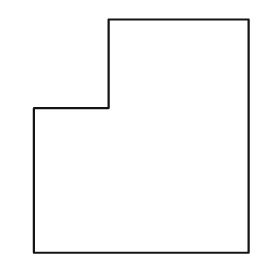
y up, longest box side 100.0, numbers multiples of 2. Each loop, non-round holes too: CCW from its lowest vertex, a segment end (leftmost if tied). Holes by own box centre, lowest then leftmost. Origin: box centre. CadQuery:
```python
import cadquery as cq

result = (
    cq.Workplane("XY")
    .moveTo(-46.0, -50.0)
    .lineTo(46.0, -50.0)
    .lineTo(46.0, 50.0)
    .lineTo(-14.0, 50.0)
    .lineTo(-14.0, 12.0)
    .lineTo(-46.0, 12.0)
    .close()
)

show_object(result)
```